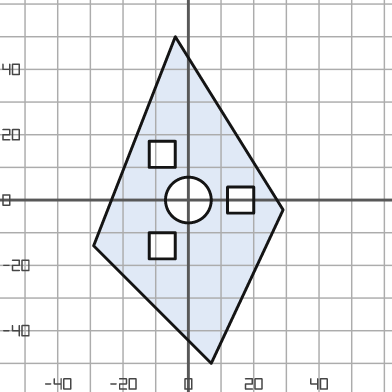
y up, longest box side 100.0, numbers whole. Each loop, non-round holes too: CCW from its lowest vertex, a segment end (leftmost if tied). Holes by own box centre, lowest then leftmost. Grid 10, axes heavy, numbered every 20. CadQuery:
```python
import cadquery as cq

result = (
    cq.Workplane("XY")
    .moveTo(7.0, -50.0)
    .lineTo(29.0, -3.0)
    .lineTo(-4.0, 50.0)
    .lineTo(-29.0, -14.0)
    .close()
    .moveTo(-12.0, -18.0)
    .lineTo(-4.0, -18.0)
    .lineTo(-4.0, -10.0)
    .lineTo(-12.0, -10.0)
    .close()
    .moveTo(0.0, 0.0)
    .circle(7.0)
    .moveTo(12.0, -4.0)
    .lineTo(20.0, -4.0)
    .lineTo(20.0, 4.0)
    .lineTo(12.0, 4.0)
    .close()
    .moveTo(-12.0, 10.0)
    .lineTo(-4.0, 10.0)
    .lineTo(-4.0, 18.0)
    .lineTo(-12.0, 18.0)
    .close()
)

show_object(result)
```